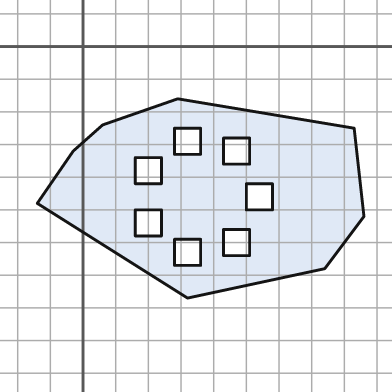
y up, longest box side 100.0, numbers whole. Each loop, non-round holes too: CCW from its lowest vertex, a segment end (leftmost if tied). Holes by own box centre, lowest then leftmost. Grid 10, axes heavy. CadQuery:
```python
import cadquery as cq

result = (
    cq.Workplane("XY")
    .moveTo(32.0, -77.0)
    .lineTo(74.0, -68.0)
    .lineTo(86.0, -52.0)
    .lineTo(83.0, -25.0)
    .lineTo(29.0, -16.0)
    .lineTo(6.0, -24.0)
    .lineTo(-3.0, -32.0)
    .lineTo(-14.0, -48.0)
    .close()
    .moveTo(28.0, -67.0)
    .lineTo(36.0, -67.0)
    .lineTo(36.0, -59.0)
    .lineTo(28.0, -59.0)
    .close()
    .moveTo(43.0, -64.0)
    .lineTo(51.0, -64.0)
    .lineTo(51.0, -56.0)
    .lineTo(43.0, -56.0)
    .close()
    .moveTo(16.0, -58.0)
    .lineTo(24.0, -58.0)
    .lineTo(24.0, -50.0)
    .lineTo(16.0, -50.0)
    .close()
    .moveTo(50.0, -50.0)
    .lineTo(58.0, -50.0)
    .lineTo(58.0, -42.0)
    .lineTo(50.0, -42.0)
    .close()
    .moveTo(16.0, -42.0)
    .lineTo(24.0, -42.0)
    .lineTo(24.0, -34.0)
    .lineTo(16.0, -34.0)
    .close()
    .moveTo(43.0, -36.0)
    .lineTo(51.0, -36.0)
    .lineTo(51.0, -28.0)
    .lineTo(43.0, -28.0)
    .close()
    .moveTo(28.0, -33.0)
    .lineTo(36.0, -33.0)
    .lineTo(36.0, -25.0)
    .lineTo(28.0, -25.0)
    .close()
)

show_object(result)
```